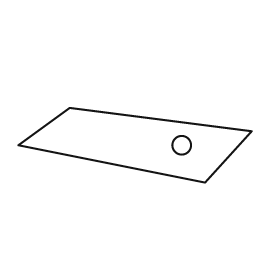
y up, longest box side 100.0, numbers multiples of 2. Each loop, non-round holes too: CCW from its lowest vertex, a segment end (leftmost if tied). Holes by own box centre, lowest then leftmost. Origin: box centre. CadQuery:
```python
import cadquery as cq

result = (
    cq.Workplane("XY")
    .moveTo(30.0, -16.0)
    .lineTo(50.0, 6.0)
    .lineTo(-28.0, 16.0)
    .lineTo(-50.0, 0.0)
    .close()
    .moveTo(20.0, 0.0)
    .circle(4.0)
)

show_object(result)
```